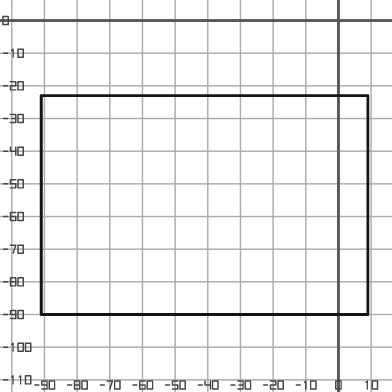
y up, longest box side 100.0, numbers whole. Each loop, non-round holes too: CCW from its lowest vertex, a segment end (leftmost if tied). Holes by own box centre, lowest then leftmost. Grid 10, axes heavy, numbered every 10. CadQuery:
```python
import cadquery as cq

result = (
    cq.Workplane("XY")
    .moveTo(-91.0, -90.0)
    .lineTo(9.0, -90.0)
    .lineTo(9.0, -23.0)
    .lineTo(-91.0, -23.0)
    .close()
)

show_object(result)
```